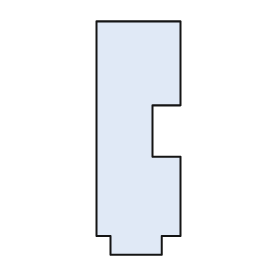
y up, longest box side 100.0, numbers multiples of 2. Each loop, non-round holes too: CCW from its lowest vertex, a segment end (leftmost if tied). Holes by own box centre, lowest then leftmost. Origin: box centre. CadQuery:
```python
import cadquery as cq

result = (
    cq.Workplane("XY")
    .moveTo(-12.0, -50.0)
    .lineTo(10.0, -50.0)
    .lineTo(10.0, -42.0)
    .lineTo(18.0, -42.0)
    .lineTo(18.0, -8.0)
    .lineTo(6.0, -8.0)
    .lineTo(6.0, 14.0)
    .lineTo(18.0, 14.0)
    .lineTo(18.0, 50.0)
    .lineTo(-18.0, 50.0)
    .lineTo(-18.0, -42.0)
    .lineTo(-12.0, -42.0)
    .close()
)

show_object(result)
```